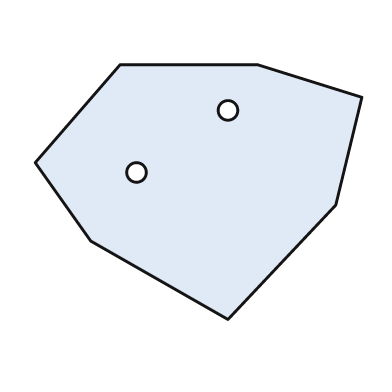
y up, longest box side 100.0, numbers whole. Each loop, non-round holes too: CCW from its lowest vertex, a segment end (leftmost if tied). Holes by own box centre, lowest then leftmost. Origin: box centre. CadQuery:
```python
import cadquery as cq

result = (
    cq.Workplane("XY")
    .moveTo(9.0, -39.0)
    .lineTo(42.0, -4.0)
    .lineTo(50.0, 29.0)
    .lineTo(18.0, 39.0)
    .lineTo(-24.0, 39.0)
    .lineTo(-50.0, 9.0)
    .lineTo(-33.0, -15.0)
    .close()
    .moveTo(-19.0, 6.0)
    .circle(3.0)
    .moveTo(9.0, 25.0)
    .circle(3.0)
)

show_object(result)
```